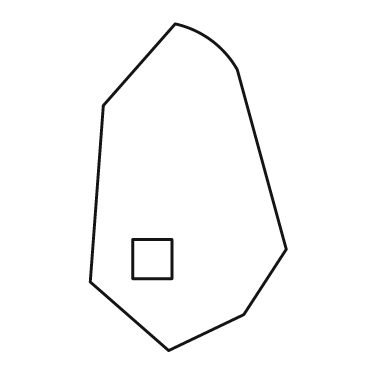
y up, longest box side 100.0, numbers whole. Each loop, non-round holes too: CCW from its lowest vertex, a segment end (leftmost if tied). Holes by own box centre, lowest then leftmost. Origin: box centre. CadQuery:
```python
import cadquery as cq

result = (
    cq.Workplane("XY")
    .moveTo(-6.0, -50.0)
    .lineTo(17.0, -39.0)
    .lineTo(30.0, -19.0)
    .lineTo(15.0, 36.0)
    .threePointArc((7.0, 45.0), (-4.0, 50.0))
    .lineTo(-26.0, 25.0)
    .lineTo(-30.0, -29.0)
    .close()
    .moveTo(-17.0, -28.0)
    .lineTo(-5.0, -28.0)
    .lineTo(-5.0, -16.0)
    .lineTo(-17.0, -16.0)
    .close()
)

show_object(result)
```